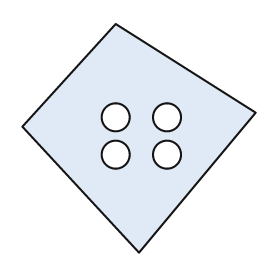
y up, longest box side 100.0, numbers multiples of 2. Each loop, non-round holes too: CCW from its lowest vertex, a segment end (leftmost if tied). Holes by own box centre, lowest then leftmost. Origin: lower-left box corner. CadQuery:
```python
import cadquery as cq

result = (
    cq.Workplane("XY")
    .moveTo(50.0, 0.0)
    .lineTo(100.0, 60.0)
    .lineTo(40.0, 98.0)
    .lineTo(0.0, 54.0)
    .close()
    .moveTo(40.0, 42.0)
    .circle(6.0)
    .moveTo(62.0, 42.0)
    .circle(6.0)
    .moveTo(40.0, 58.0)
    .circle(6.0)
    .moveTo(62.0, 58.0)
    .circle(6.0)
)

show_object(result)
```